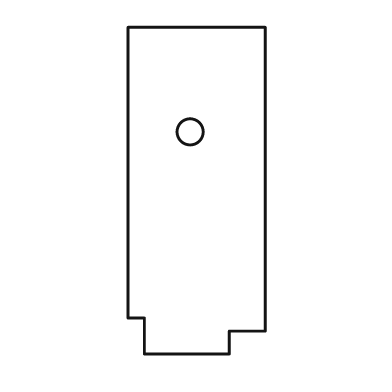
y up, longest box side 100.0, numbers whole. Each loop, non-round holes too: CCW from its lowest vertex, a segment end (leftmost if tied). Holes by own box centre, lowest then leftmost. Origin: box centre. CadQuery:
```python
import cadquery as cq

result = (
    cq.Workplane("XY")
    .moveTo(-16.0, -50.0)
    .lineTo(10.0, -50.0)
    .lineTo(10.0, -43.0)
    .lineTo(21.0, -43.0)
    .lineTo(21.0, 50.0)
    .lineTo(-21.0, 50.0)
    .lineTo(-21.0, -39.0)
    .lineTo(-16.0, -39.0)
    .close()
    .moveTo(-2.0, 18.0)
    .circle(4.0)
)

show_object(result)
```